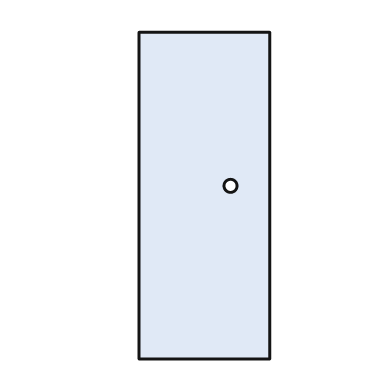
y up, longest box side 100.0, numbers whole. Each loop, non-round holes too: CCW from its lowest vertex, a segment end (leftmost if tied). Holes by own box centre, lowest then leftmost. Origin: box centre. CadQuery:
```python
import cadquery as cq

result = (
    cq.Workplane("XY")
    .moveTo(-20.0, -50.0)
    .lineTo(20.0, -50.0)
    .lineTo(20.0, 50.0)
    .lineTo(-20.0, 50.0)
    .close()
    .moveTo(8.0, 3.0)
    .circle(2.0)
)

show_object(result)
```